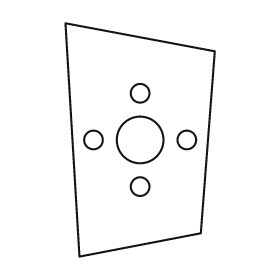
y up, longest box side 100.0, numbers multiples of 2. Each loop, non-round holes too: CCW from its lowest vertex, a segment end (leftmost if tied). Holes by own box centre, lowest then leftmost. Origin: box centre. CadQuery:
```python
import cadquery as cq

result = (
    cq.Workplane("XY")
    .moveTo(-26.0, -50.0)
    .lineTo(26.0, -40.0)
    .lineTo(32.0, 38.0)
    .lineTo(-32.0, 50.0)
    .close()
    .moveTo(0.0, -20.0)
    .circle(4.0)
    .moveTo(-20.0, 0.0)
    .circle(4.0)
    .moveTo(0.0, 0.0)
    .circle(10.0)
    .moveTo(20.0, 0.0)
    .circle(4.0)
    .moveTo(0.0, 20.0)
    .circle(4.0)
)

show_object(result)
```